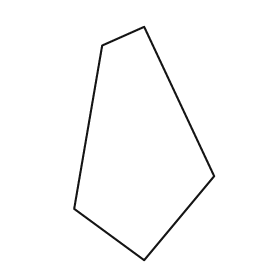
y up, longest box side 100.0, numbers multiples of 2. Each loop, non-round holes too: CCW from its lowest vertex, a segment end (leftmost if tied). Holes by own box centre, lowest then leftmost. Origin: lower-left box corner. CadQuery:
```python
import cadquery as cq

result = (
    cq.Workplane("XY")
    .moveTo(30.0, 0.0)
    .lineTo(60.0, 36.0)
    .lineTo(30.0, 100.0)
    .lineTo(12.0, 92.0)
    .lineTo(0.0, 22.0)
    .close()
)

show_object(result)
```